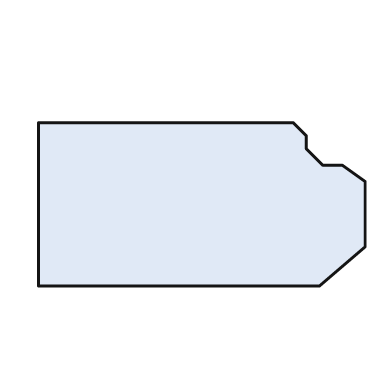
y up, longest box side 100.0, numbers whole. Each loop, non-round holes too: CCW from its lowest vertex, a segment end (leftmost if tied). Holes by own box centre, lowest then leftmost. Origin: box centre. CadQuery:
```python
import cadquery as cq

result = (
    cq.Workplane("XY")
    .moveTo(-50.0, -25.0)
    .lineTo(36.0, -25.0)
    .lineTo(50.0, -13.0)
    .lineTo(50.0, 7.0)
    .lineTo(43.0, 12.0)
    .lineTo(37.0, 12.0)
    .lineTo(32.0, 17.0)
    .lineTo(32.0, 21.0)
    .lineTo(28.0, 25.0)
    .lineTo(-50.0, 25.0)
    .close()
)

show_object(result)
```